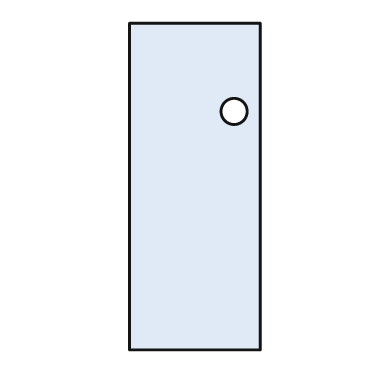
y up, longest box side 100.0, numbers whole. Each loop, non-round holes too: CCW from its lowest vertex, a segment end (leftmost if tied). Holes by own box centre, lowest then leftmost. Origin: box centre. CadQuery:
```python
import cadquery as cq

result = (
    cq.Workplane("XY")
    .moveTo(-20.0, -50.0)
    .lineTo(20.0, -50.0)
    .lineTo(20.0, 50.0)
    .lineTo(-20.0, 50.0)
    .close()
    .moveTo(12.0, 23.0)
    .circle(4.0)
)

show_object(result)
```